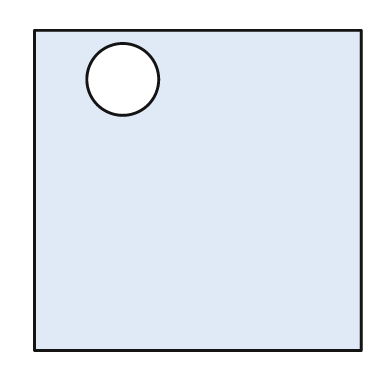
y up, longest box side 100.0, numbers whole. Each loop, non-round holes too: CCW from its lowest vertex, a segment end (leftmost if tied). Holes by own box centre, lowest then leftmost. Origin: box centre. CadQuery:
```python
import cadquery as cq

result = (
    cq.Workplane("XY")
    .moveTo(-50.0, -49.0)
    .lineTo(50.0, -49.0)
    .lineTo(50.0, 49.0)
    .lineTo(-50.0, 49.0)
    .close()
    .moveTo(-23.0, 34.0)
    .circle(11.0)
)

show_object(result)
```